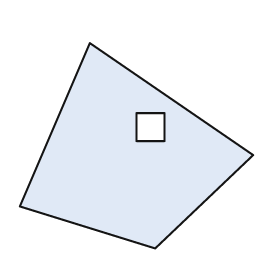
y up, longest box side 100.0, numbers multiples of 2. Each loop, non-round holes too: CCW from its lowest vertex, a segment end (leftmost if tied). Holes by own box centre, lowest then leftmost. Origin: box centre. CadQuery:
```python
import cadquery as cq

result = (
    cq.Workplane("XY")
    .moveTo(8.0, -44.0)
    .lineTo(50.0, -4.0)
    .lineTo(-20.0, 44.0)
    .lineTo(-50.0, -26.0)
    .close()
    .moveTo(0.0, 2.0)
    .lineTo(12.0, 2.0)
    .lineTo(12.0, 14.0)
    .lineTo(0.0, 14.0)
    .close()
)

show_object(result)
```